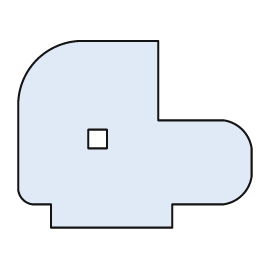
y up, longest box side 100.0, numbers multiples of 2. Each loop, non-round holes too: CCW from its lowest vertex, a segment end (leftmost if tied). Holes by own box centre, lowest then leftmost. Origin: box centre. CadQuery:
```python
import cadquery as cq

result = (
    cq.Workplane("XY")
    .moveTo(-36.0, -40.0)
    .lineTo(16.0, -40.0)
    .lineTo(16.0, -30.0)
    .lineTo(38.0, -30.0)
    .threePointArc((46.0, -26.0), (50.0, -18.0))
    .lineTo(50.0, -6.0)
    .threePointArc((46.0, 2.0), (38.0, 6.0))
    .lineTo(10.0, 6.0)
    .lineTo(10.0, 40.0)
    .lineTo(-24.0, 40.0)
    .threePointArc((-42.0, 32.0), (-50.0, 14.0))
    .lineTo(-50.0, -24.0)
    .threePointArc((-48.0, -28.0), (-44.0, -30.0))
    .lineTo(-36.0, -30.0)
    .close()
    .moveTo(-20.0, -6.0)
    .lineTo(-12.0, -6.0)
    .lineTo(-12.0, 2.0)
    .lineTo(-20.0, 2.0)
    .close()
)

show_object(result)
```